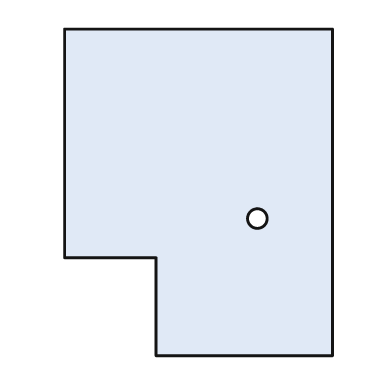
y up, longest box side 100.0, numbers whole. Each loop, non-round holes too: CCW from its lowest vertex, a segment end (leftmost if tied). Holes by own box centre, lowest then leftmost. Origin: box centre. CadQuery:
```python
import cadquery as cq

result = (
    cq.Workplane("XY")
    .moveTo(-13.0, -50.0)
    .lineTo(41.0, -50.0)
    .lineTo(41.0, 50.0)
    .lineTo(-41.0, 50.0)
    .lineTo(-41.0, -20.0)
    .lineTo(-13.0, -20.0)
    .close()
    .moveTo(18.0, -8.0)
    .circle(3.0)
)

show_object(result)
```